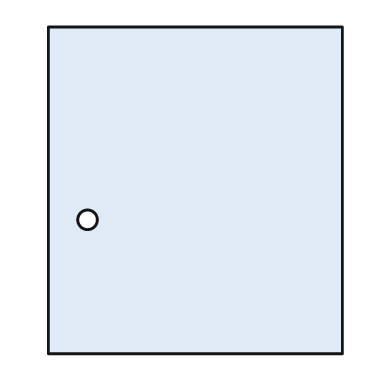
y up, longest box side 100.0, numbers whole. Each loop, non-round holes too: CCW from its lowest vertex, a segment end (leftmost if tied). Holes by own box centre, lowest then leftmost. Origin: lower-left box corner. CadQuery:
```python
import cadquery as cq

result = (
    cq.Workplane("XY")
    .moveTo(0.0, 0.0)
    .lineTo(90.0, 0.0)
    .lineTo(90.0, 100.0)
    .lineTo(0.0, 100.0)
    .close()
    .moveTo(12.0, 41.0)
    .circle(3.0)
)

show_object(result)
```